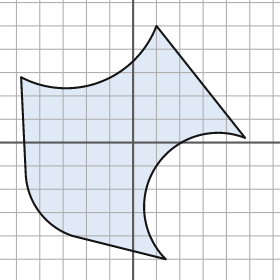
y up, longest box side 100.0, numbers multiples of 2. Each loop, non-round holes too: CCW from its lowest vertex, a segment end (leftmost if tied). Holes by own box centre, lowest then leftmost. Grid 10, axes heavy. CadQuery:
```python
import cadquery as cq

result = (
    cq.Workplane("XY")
    .moveTo(14.0, -50.0)
    .threePointArc((10.0, -10.0), (48.0, 2.0))
    .lineTo(10.0, 50.0)
    .threePointArc((-14.0, 26.0), (-48.0, 28.0))
    .lineTo(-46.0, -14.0)
    .threePointArc((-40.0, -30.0), (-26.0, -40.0))
    .close()
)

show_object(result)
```